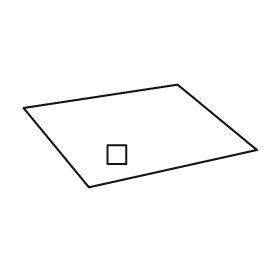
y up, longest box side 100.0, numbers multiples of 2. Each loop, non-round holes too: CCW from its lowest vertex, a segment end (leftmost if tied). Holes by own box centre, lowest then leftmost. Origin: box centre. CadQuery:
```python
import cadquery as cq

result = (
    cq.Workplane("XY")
    .moveTo(-22.0, -22.0)
    .lineTo(50.0, -6.0)
    .lineTo(16.0, 22.0)
    .lineTo(-50.0, 12.0)
    .close()
    .moveTo(-14.0, -12.0)
    .lineTo(-6.0, -12.0)
    .lineTo(-6.0, -4.0)
    .lineTo(-14.0, -4.0)
    .close()
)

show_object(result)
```